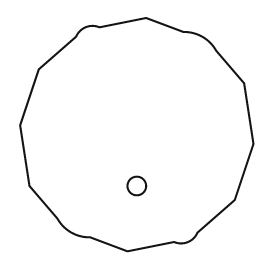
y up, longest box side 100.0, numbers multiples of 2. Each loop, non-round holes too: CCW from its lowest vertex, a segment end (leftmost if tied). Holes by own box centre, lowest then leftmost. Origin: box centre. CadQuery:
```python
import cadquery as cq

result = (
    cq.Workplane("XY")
    .moveTo(-4.0, -50.0)
    .lineTo(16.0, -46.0)
    .threePointArc((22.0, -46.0), (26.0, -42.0))
    .lineTo(42.0, -28.0)
    .lineTo(50.0, -4.0)
    .lineTo(46.0, 22.0)
    .lineTo(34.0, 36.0)
    .threePointArc((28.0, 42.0), (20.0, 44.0))
    .lineTo(4.0, 50.0)
    .lineTo(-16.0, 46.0)
    .threePointArc((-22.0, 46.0), (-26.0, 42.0))
    .lineTo(-42.0, 28.0)
    .lineTo(-50.0, 4.0)
    .lineTo(-46.0, -22.0)
    .lineTo(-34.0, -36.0)
    .threePointArc((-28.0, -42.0), (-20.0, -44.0))
    .close()
    .moveTo(0.0, -22.0)
    .circle(4.0)
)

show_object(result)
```